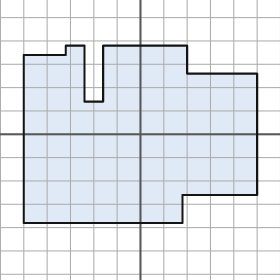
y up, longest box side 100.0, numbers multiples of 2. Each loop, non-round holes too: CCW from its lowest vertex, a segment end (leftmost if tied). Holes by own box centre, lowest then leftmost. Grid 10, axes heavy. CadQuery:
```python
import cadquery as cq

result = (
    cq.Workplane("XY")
    .moveTo(-50.0, -38.0)
    .lineTo(18.0, -38.0)
    .lineTo(18.0, -26.0)
    .lineTo(50.0, -26.0)
    .lineTo(50.0, 26.0)
    .lineTo(20.0, 26.0)
    .lineTo(20.0, 38.0)
    .lineTo(-16.0, 38.0)
    .lineTo(-16.0, 14.0)
    .lineTo(-24.0, 14.0)
    .lineTo(-24.0, 38.0)
    .lineTo(-32.0, 38.0)
    .lineTo(-32.0, 34.0)
    .lineTo(-50.0, 34.0)
    .close()
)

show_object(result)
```